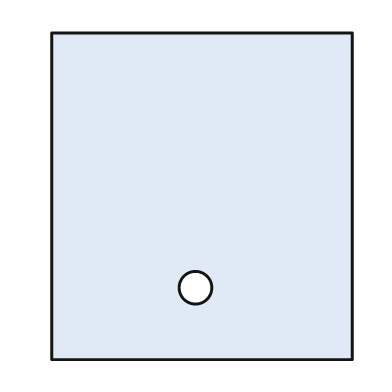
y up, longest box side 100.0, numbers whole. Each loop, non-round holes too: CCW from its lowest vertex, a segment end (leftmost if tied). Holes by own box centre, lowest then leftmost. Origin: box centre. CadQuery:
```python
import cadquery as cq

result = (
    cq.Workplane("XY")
    .moveTo(-46.0, -50.0)
    .lineTo(46.0, -50.0)
    .lineTo(46.0, 50.0)
    .lineTo(-46.0, 50.0)
    .close()
    .moveTo(-2.0, -28.0)
    .circle(5.0)
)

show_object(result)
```